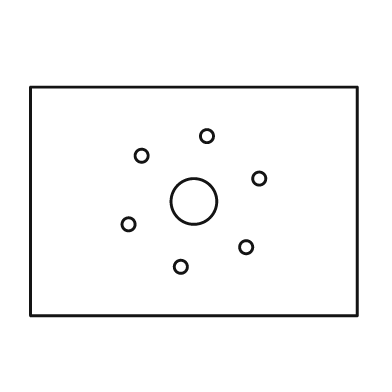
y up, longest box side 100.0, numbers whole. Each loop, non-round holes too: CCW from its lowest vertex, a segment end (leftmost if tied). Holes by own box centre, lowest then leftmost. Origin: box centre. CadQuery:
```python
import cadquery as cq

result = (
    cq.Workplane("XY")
    .moveTo(-50.0, -35.0)
    .lineTo(50.0, -35.0)
    .lineTo(50.0, 35.0)
    .lineTo(-50.0, 35.0)
    .close()
    .moveTo(-4.0, -20.0)
    .circle(2.0)
    .moveTo(16.0, -14.0)
    .circle(2.0)
    .moveTo(-20.0, -7.0)
    .circle(2.0)
    .moveTo(0.0, 0.0)
    .circle(7.0)
    .moveTo(20.0, 7.0)
    .circle(2.0)
    .moveTo(-16.0, 14.0)
    .circle(2.0)
    .moveTo(4.0, 20.0)
    .circle(2.0)
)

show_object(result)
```